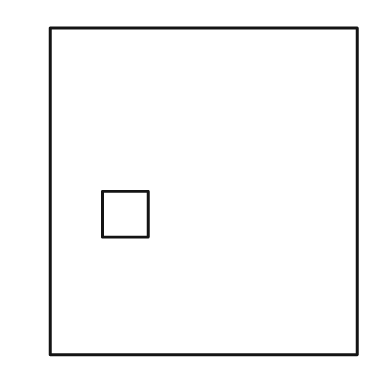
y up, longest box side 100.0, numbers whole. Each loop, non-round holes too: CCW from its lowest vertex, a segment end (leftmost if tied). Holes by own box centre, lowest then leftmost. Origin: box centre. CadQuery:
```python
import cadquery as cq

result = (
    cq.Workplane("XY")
    .moveTo(-47.0, -50.0)
    .lineTo(47.0, -50.0)
    .lineTo(47.0, 50.0)
    .lineTo(-47.0, 50.0)
    .close()
    .moveTo(-31.0, -14.0)
    .lineTo(-17.0, -14.0)
    .lineTo(-17.0, 0.0)
    .lineTo(-31.0, 0.0)
    .close()
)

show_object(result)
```